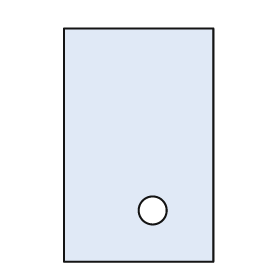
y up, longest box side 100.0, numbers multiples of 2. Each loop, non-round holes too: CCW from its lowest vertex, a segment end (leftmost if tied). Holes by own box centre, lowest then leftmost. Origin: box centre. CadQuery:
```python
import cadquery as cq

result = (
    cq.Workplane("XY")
    .moveTo(-32.0, -50.0)
    .lineTo(32.0, -50.0)
    .lineTo(32.0, 50.0)
    .lineTo(-32.0, 50.0)
    .close()
    .moveTo(6.0, -28.0)
    .circle(6.0)
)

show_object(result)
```